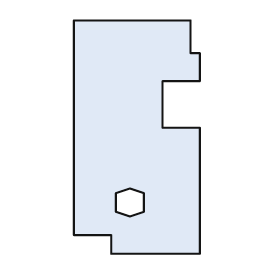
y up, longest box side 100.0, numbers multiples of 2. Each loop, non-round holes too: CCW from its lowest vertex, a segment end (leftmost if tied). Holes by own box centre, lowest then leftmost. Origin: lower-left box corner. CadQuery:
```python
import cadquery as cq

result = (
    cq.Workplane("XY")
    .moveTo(16.0, 0.0)
    .lineTo(54.0, 0.0)
    .lineTo(54.0, 54.0)
    .lineTo(38.0, 54.0)
    .lineTo(38.0, 74.0)
    .lineTo(54.0, 74.0)
    .lineTo(54.0, 86.0)
    .lineTo(50.0, 86.0)
    .lineTo(50.0, 100.0)
    .lineTo(0.0, 100.0)
    .lineTo(0.0, 8.0)
    .lineTo(16.0, 8.0)
    .close()
    .moveTo(24.0, 16.0)
    .lineTo(30.0, 18.0)
    .lineTo(30.0, 26.0)
    .lineTo(24.0, 28.0)
    .lineTo(18.0, 26.0)
    .lineTo(18.0, 18.0)
    .close()
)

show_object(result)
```